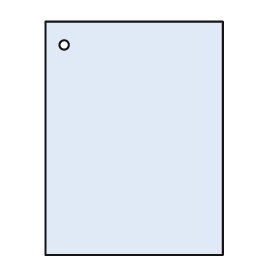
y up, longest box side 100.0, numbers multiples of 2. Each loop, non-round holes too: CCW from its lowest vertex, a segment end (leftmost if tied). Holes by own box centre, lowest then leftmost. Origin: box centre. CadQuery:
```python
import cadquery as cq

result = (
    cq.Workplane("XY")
    .moveTo(-38.0, -50.0)
    .lineTo(38.0, -50.0)
    .lineTo(38.0, 50.0)
    .lineTo(-38.0, 50.0)
    .close()
    .moveTo(-30.0, 40.0)
    .circle(2.0)
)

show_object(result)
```